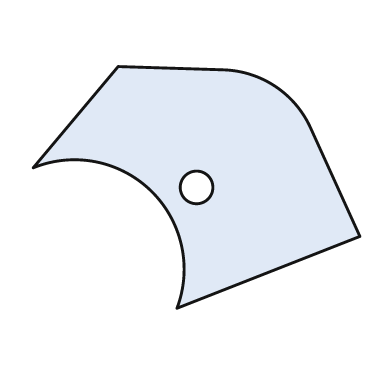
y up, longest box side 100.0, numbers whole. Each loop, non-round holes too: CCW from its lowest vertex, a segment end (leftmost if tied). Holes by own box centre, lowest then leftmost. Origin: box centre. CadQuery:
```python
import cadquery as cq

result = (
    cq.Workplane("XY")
    .moveTo(-6.0, -37.0)
    .lineTo(50.0, -15.0)
    .lineTo(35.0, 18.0)
    .threePointArc((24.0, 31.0), (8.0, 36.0))
    .lineTo(-24.0, 37.0)
    .lineTo(-50.0, 6.0)
    .threePointArc((-14.0, -1.0), (-6.0, -37.0))
    .close()
    .moveTo(0.0, 0.0)
    .circle(5.0)
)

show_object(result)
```